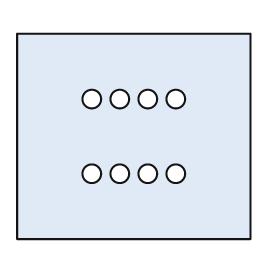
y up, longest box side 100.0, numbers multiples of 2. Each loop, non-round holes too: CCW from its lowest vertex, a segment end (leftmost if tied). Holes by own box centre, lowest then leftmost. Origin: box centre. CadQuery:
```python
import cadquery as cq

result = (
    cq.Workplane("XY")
    .moveTo(-50.0, -44.0)
    .lineTo(50.0, -44.0)
    .lineTo(50.0, 44.0)
    .lineTo(-50.0, 44.0)
    .close()
    .moveTo(-18.0, -16.0)
    .circle(4.0)
    .moveTo(-6.0, -16.0)
    .circle(4.0)
    .moveTo(6.0, -16.0)
    .circle(4.0)
    .moveTo(18.0, -16.0)
    .circle(4.0)
    .moveTo(-18.0, 16.0)
    .circle(4.0)
    .moveTo(-6.0, 16.0)
    .circle(4.0)
    .moveTo(6.0, 16.0)
    .circle(4.0)
    .moveTo(18.0, 16.0)
    .circle(4.0)
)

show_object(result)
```